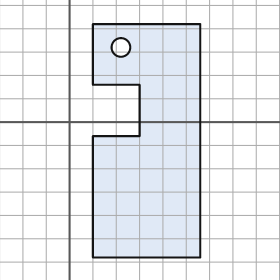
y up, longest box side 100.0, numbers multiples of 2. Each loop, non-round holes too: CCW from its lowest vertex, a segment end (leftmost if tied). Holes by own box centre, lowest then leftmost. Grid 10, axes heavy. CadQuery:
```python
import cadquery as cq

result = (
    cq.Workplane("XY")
    .moveTo(10.0, -58.0)
    .lineTo(56.0, -58.0)
    .lineTo(56.0, 42.0)
    .lineTo(10.0, 42.0)
    .lineTo(10.0, 16.0)
    .lineTo(30.0, 16.0)
    .lineTo(30.0, -6.0)
    .lineTo(10.0, -6.0)
    .close()
    .moveTo(22.0, 32.0)
    .circle(4.0)
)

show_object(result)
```